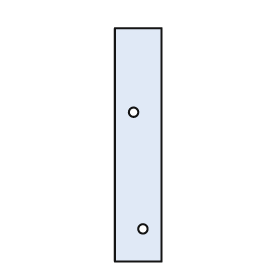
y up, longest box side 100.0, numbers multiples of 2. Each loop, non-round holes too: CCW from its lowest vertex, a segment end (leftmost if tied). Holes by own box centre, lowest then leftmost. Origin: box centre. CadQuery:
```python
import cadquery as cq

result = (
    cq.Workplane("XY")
    .moveTo(-10.0, -50.0)
    .lineTo(10.0, -50.0)
    .lineTo(10.0, 50.0)
    .lineTo(-10.0, 50.0)
    .close()
    .moveTo(2.0, -36.0)
    .circle(2.0)
    .moveTo(-2.0, 14.0)
    .circle(2.0)
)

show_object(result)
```